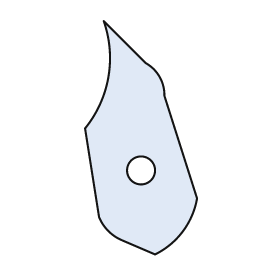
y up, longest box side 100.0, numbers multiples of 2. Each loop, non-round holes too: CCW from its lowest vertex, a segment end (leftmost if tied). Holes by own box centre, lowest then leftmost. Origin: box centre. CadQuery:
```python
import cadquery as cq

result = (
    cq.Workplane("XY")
    .moveTo(6.0, -50.0)
    .threePointArc((18.0, -40.0), (24.0, -26.0))
    .lineTo(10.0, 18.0)
    .threePointArc((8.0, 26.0), (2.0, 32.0))
    .lineTo(-16.0, 50.0)
    .threePointArc((-14.0, 26.0), (-24.0, 4.0))
    .lineTo(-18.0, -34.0)
    .threePointArc((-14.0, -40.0), (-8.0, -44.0))
    .close()
    .moveTo(0.0, -14.0)
    .circle(6.0)
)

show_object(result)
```